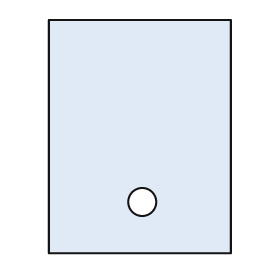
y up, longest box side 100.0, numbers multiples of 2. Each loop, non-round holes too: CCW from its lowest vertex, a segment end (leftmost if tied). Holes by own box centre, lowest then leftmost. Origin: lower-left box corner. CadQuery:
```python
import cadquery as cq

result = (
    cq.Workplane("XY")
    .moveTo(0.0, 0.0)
    .lineTo(78.0, 0.0)
    .lineTo(78.0, 100.0)
    .lineTo(0.0, 100.0)
    .close()
    .moveTo(40.0, 22.0)
    .circle(6.0)
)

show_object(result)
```